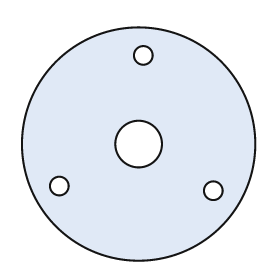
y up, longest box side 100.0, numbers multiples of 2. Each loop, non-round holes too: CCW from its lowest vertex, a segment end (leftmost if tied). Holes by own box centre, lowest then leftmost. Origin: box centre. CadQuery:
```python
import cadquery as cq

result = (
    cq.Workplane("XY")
    .moveTo(0.0, 0.0)
    .circle(50.0)
    .moveTo(32.0, -20.0)
    .circle(4.0)
    .moveTo(-34.0, -18.0)
    .circle(4.0)
    .moveTo(0.0, 0.0)
    .circle(10.0)
    .moveTo(2.0, 38.0)
    .circle(4.0)
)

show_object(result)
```